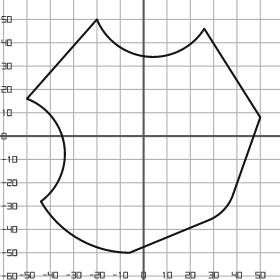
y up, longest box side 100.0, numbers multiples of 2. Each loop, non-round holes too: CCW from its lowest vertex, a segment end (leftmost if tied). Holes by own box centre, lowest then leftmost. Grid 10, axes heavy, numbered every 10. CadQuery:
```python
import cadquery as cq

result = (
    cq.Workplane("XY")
    .moveTo(-6.0, -50.0)
    .lineTo(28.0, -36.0)
    .threePointArc((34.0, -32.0), (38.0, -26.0))
    .lineTo(50.0, 8.0)
    .lineTo(26.0, 46.0)
    .threePointArc((2.0, 34.0), (-20.0, 50.0))
    .lineTo(-50.0, 16.0)
    .threePointArc((-34.0, -4.0), (-44.0, -28.0))
    .threePointArc((-28.0, -44.0), (-6.0, -50.0))
    .close()
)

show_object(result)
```